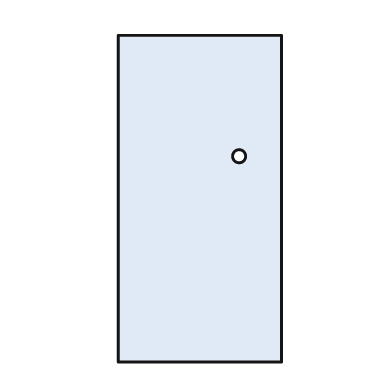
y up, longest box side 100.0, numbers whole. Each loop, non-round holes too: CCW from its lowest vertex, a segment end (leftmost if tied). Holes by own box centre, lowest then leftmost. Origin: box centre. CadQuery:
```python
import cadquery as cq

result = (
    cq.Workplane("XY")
    .moveTo(-25.0, -50.0)
    .lineTo(25.0, -50.0)
    .lineTo(25.0, 50.0)
    .lineTo(-25.0, 50.0)
    .close()
    .moveTo(12.0, 13.0)
    .circle(2.0)
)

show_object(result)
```